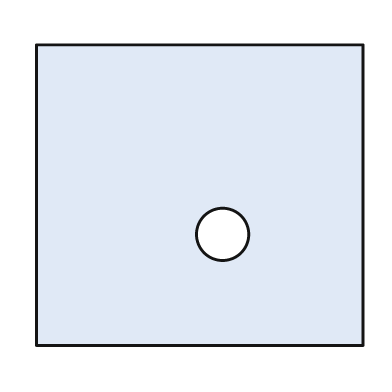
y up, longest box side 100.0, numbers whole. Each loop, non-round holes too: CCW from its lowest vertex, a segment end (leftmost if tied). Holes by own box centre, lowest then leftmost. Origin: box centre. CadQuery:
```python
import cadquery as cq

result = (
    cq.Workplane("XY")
    .moveTo(-50.0, -46.0)
    .lineTo(50.0, -46.0)
    .lineTo(50.0, 46.0)
    .lineTo(-50.0, 46.0)
    .close()
    .moveTo(7.0, -12.0)
    .circle(8.0)
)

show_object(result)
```